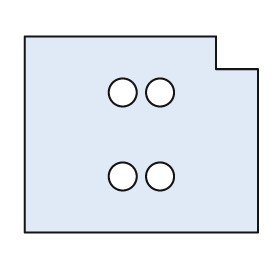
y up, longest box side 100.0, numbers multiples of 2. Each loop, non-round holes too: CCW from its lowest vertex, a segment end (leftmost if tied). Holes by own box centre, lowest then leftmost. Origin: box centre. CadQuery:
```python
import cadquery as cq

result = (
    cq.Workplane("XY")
    .moveTo(-50.0, -42.0)
    .lineTo(50.0, -42.0)
    .lineTo(50.0, 28.0)
    .lineTo(32.0, 28.0)
    .lineTo(32.0, 42.0)
    .lineTo(-50.0, 42.0)
    .close()
    .moveTo(-8.0, -18.0)
    .circle(6.0)
    .moveTo(8.0, -18.0)
    .circle(6.0)
    .moveTo(-8.0, 18.0)
    .circle(6.0)
    .moveTo(8.0, 18.0)
    .circle(6.0)
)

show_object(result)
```